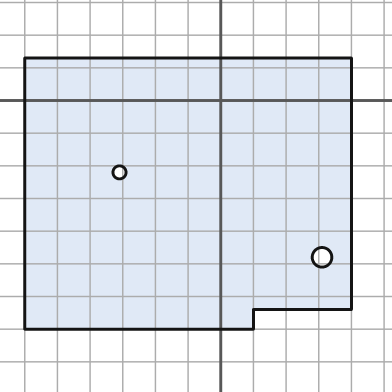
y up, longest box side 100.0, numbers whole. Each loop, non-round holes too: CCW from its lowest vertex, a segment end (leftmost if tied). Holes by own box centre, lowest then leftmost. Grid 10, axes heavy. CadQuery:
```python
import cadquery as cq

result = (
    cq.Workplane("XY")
    .moveTo(-60.0, -70.0)
    .lineTo(10.0, -70.0)
    .lineTo(10.0, -64.0)
    .lineTo(40.0, -64.0)
    .lineTo(40.0, 13.0)
    .lineTo(-60.0, 13.0)
    .close()
    .moveTo(31.0, -48.0)
    .circle(3.0)
    .moveTo(-31.0, -22.0)
    .circle(2.0)
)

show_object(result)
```